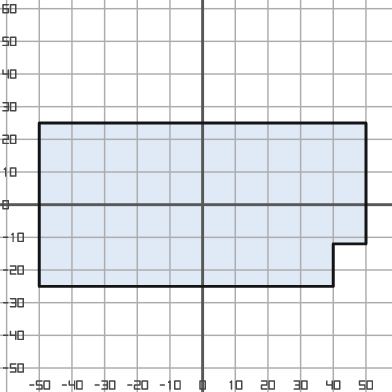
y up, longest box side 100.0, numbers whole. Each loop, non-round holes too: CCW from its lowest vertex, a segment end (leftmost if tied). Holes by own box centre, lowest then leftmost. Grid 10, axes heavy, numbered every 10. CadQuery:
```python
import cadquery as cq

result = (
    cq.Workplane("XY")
    .moveTo(-50.0, -25.0)
    .lineTo(40.0, -25.0)
    .lineTo(40.0, -12.0)
    .lineTo(50.0, -12.0)
    .lineTo(50.0, 25.0)
    .lineTo(-50.0, 25.0)
    .close()
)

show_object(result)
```